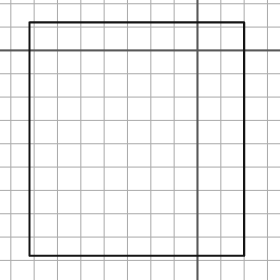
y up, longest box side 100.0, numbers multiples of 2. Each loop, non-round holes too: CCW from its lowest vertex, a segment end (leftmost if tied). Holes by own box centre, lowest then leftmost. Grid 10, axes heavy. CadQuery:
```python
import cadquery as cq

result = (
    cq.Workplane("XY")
    .moveTo(-72.0, -88.0)
    .lineTo(20.0, -88.0)
    .lineTo(20.0, 12.0)
    .lineTo(-72.0, 12.0)
    .close()
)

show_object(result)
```